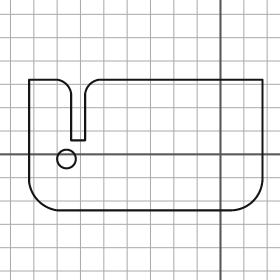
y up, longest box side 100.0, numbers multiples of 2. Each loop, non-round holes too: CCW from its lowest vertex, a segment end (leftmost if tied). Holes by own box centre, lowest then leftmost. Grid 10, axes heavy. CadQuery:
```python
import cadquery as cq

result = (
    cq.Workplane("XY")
    .moveTo(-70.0, -24.0)
    .lineTo(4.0, -24.0)
    .threePointArc((14.0, -20.0), (18.0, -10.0))
    .lineTo(18.0, 32.0)
    .lineTo(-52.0, 32.0)
    .threePointArc((-56.0, 30.0), (-58.0, 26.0))
    .lineTo(-58.0, 6.0)
    .lineTo(-64.0, 6.0)
    .lineTo(-64.0, 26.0)
    .threePointArc((-66.0, 30.0), (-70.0, 32.0))
    .lineTo(-82.0, 32.0)
    .lineTo(-82.0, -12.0)
    .threePointArc((-78.0, -20.0), (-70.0, -24.0))
    .close()
    .moveTo(-66.0, -2.0)
    .circle(4.0)
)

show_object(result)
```